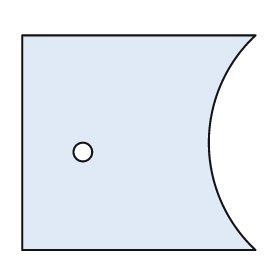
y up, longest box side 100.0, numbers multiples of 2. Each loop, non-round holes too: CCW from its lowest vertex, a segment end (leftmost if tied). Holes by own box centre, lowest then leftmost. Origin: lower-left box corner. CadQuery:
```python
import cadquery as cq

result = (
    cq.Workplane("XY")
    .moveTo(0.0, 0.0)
    .lineTo(100.0, 0.0)
    .threePointArc((80.0, 46.0), (100.0, 92.0))
    .lineTo(0.0, 92.0)
    .close()
    .moveTo(26.0, 42.0)
    .circle(4.0)
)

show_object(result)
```